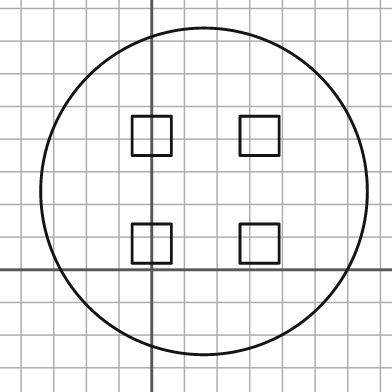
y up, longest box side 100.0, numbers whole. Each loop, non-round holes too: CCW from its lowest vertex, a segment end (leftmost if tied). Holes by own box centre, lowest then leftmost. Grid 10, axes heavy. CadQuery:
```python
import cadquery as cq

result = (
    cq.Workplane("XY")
    .moveTo(16.0, 24.0)
    .circle(50.0)
    .moveTo(-6.0, 2.0)
    .lineTo(6.0, 2.0)
    .lineTo(6.0, 14.0)
    .lineTo(-6.0, 14.0)
    .close()
    .moveTo(27.0, 2.0)
    .lineTo(39.0, 2.0)
    .lineTo(39.0, 14.0)
    .lineTo(27.0, 14.0)
    .close()
    .moveTo(-6.0, 35.0)
    .lineTo(6.0, 35.0)
    .lineTo(6.0, 47.0)
    .lineTo(-6.0, 47.0)
    .close()
    .moveTo(27.0, 35.0)
    .lineTo(39.0, 35.0)
    .lineTo(39.0, 47.0)
    .lineTo(27.0, 47.0)
    .close()
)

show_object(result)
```